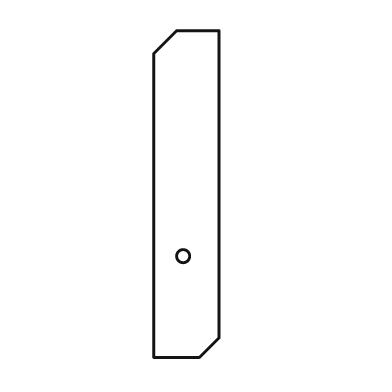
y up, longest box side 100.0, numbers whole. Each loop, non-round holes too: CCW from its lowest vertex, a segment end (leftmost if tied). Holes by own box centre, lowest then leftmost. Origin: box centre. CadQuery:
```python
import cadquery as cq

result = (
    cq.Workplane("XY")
    .moveTo(-10.0, -50.0)
    .lineTo(4.0, -50.0)
    .lineTo(10.0, -44.0)
    .lineTo(10.0, 50.0)
    .lineTo(-3.0, 50.0)
    .lineTo(-10.0, 43.0)
    .close()
    .moveTo(-1.0, -19.0)
    .circle(2.0)
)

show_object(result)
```